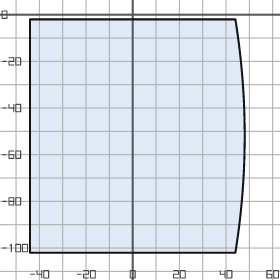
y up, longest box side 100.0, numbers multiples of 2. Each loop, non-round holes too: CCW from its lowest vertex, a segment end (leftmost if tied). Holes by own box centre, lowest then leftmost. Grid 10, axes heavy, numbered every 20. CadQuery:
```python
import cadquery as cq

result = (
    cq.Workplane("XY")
    .moveTo(-44.0, -102.0)
    .lineTo(44.0, -102.0)
    .threePointArc((48.0, -52.0), (44.0, -2.0))
    .lineTo(-44.0, -2.0)
    .close()
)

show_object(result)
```